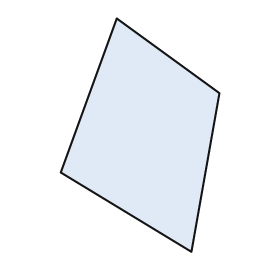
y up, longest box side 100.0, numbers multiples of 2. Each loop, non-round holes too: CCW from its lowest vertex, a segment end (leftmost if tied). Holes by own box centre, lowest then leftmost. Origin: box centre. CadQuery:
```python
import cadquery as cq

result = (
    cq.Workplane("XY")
    .moveTo(22.0, -50.0)
    .lineTo(34.0, 18.0)
    .lineTo(-10.0, 50.0)
    .lineTo(-34.0, -16.0)
    .close()
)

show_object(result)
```